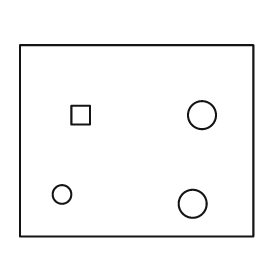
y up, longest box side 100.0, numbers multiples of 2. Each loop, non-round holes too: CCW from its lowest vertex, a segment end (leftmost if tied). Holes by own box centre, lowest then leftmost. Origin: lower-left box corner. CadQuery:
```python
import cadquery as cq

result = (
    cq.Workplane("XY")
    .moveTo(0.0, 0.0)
    .lineTo(100.0, 0.0)
    .lineTo(100.0, 82.0)
    .lineTo(0.0, 82.0)
    .close()
    .moveTo(74.0, 14.0)
    .circle(6.0)
    .moveTo(18.0, 18.0)
    .circle(4.0)
    .moveTo(22.0, 48.0)
    .lineTo(30.0, 48.0)
    .lineTo(30.0, 56.0)
    .lineTo(22.0, 56.0)
    .close()
    .moveTo(78.0, 52.0)
    .circle(6.0)
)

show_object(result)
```